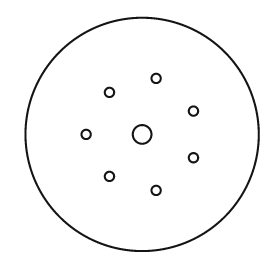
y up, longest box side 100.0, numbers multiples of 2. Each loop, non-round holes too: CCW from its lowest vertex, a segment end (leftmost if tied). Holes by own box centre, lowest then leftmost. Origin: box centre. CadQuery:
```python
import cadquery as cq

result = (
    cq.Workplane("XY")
    .moveTo(0.0, 0.0)
    .circle(50.0)
    .moveTo(6.0, -24.0)
    .circle(2.0)
    .moveTo(-14.0, -18.0)
    .circle(2.0)
    .moveTo(22.0, -10.0)
    .circle(2.0)
    .moveTo(-24.0, 0.0)
    .circle(2.0)
    .moveTo(0.0, 0.0)
    .circle(4.0)
    .moveTo(22.0, 10.0)
    .circle(2.0)
    .moveTo(-14.0, 18.0)
    .circle(2.0)
    .moveTo(6.0, 24.0)
    .circle(2.0)
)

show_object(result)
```